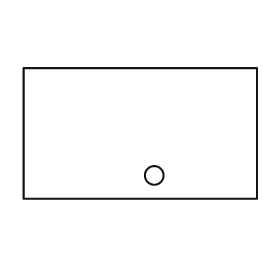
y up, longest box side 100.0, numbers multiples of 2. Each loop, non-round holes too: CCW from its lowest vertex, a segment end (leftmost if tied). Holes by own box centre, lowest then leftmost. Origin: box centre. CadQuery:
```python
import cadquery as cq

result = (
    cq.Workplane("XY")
    .moveTo(-50.0, -28.0)
    .lineTo(50.0, -28.0)
    .lineTo(50.0, 28.0)
    .lineTo(-50.0, 28.0)
    .close()
    .moveTo(6.0, -18.0)
    .circle(4.0)
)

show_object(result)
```